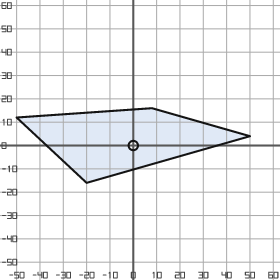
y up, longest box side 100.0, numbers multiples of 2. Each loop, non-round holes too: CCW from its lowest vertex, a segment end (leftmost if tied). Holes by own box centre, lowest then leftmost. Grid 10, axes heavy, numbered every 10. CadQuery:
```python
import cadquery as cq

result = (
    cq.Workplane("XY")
    .moveTo(-20.0, -16.0)
    .lineTo(50.0, 4.0)
    .lineTo(8.0, 16.0)
    .lineTo(-50.0, 12.0)
    .close()
    .moveTo(0.0, 0.0)
    .circle(2.0)
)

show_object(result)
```